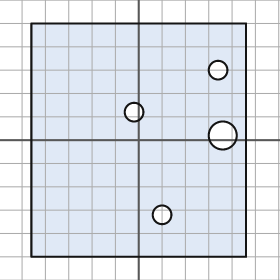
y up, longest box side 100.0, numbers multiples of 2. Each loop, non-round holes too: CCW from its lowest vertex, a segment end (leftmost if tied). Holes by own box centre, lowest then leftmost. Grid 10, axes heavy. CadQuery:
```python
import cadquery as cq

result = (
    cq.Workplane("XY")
    .moveTo(-46.0, -50.0)
    .lineTo(46.0, -50.0)
    .lineTo(46.0, 50.0)
    .lineTo(-46.0, 50.0)
    .close()
    .moveTo(10.0, -32.0)
    .circle(4.0)
    .moveTo(36.0, 2.0)
    .circle(6.0)
    .moveTo(-2.0, 12.0)
    .circle(4.0)
    .moveTo(34.0, 30.0)
    .circle(4.0)
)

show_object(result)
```